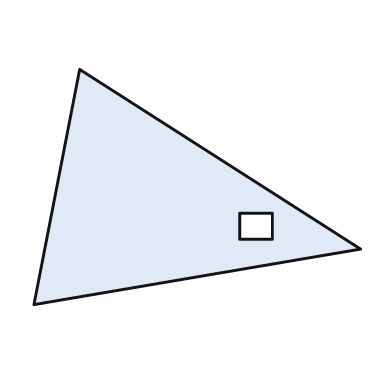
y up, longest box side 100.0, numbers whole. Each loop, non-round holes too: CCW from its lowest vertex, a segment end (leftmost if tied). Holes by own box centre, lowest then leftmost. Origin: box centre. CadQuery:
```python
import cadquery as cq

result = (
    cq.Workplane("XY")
    .moveTo(-50.0, -36.0)
    .lineTo(50.0, -19.0)
    .lineTo(-36.0, 36.0)
    .close()
    .moveTo(13.0, -16.0)
    .lineTo(23.0, -16.0)
    .lineTo(23.0, -8.0)
    .lineTo(13.0, -8.0)
    .close()
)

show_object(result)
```